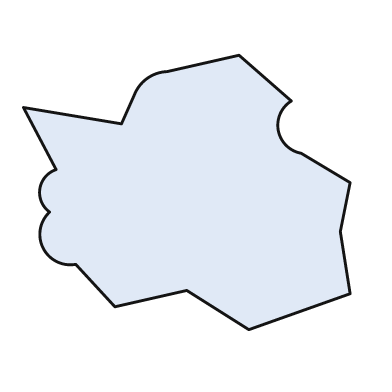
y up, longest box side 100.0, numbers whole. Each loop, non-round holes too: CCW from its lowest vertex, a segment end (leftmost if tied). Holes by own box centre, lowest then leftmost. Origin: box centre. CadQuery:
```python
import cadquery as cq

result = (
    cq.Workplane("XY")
    .moveTo(19.0, -42.0)
    .lineTo(50.0, -31.0)
    .lineTo(47.0, -12.0)
    .lineTo(50.0, 3.0)
    .lineTo(35.0, 12.0)
    .threePointArc((28.0, 19.0), (32.0, 28.0))
    .lineTo(16.0, 42.0)
    .lineTo(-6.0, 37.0)
    .threePointArc((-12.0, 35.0), (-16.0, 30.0))
    .lineTo(-20.0, 21.0)
    .lineTo(-50.0, 26.0)
    .lineTo(-40.0, 7.0)
    .threePointArc((-45.0, 1.0), (-42.0, -6.0))
    .threePointArc((-44.0, -17.0), (-34.0, -22.0))
    .lineTo(-22.0, -35.0)
    .lineTo(0.0, -30.0)
    .close()
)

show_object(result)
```